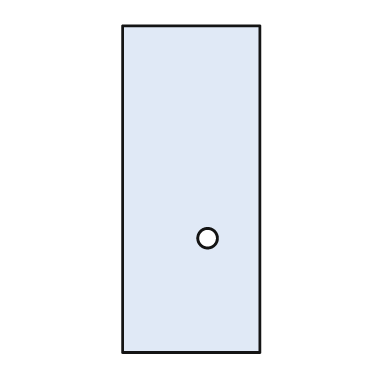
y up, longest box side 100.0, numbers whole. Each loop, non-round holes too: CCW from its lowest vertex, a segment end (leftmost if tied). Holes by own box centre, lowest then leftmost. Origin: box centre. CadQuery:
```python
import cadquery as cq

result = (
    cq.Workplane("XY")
    .moveTo(-21.0, -50.0)
    .lineTo(21.0, -50.0)
    .lineTo(21.0, 50.0)
    .lineTo(-21.0, 50.0)
    .close()
    .moveTo(5.0, -15.0)
    .circle(3.0)
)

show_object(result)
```